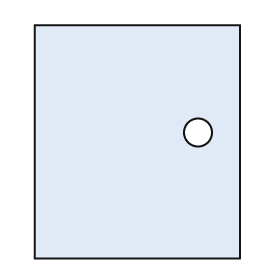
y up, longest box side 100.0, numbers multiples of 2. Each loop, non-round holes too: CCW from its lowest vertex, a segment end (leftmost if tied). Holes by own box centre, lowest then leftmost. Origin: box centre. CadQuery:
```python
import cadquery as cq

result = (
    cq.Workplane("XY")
    .moveTo(-44.0, -50.0)
    .lineTo(44.0, -50.0)
    .lineTo(44.0, 50.0)
    .lineTo(-44.0, 50.0)
    .close()
    .moveTo(26.0, 4.0)
    .circle(6.0)
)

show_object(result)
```